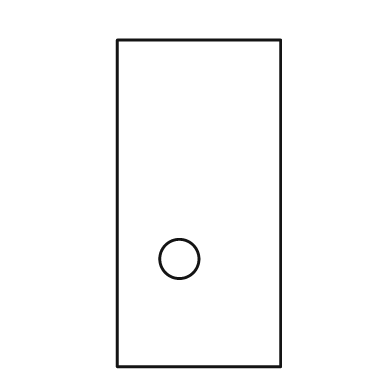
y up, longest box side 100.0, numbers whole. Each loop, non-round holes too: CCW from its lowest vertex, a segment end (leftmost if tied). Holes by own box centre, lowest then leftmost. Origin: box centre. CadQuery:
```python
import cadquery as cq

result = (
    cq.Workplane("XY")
    .moveTo(-25.0, -50.0)
    .lineTo(25.0, -50.0)
    .lineTo(25.0, 50.0)
    .lineTo(-25.0, 50.0)
    .close()
    .moveTo(-6.0, -17.0)
    .circle(6.0)
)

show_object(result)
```